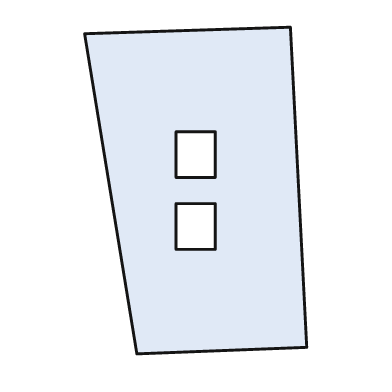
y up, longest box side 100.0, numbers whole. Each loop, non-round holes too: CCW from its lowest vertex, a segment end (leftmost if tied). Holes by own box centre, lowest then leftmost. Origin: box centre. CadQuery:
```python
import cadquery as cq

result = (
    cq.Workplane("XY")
    .moveTo(-18.0, -50.0)
    .lineTo(34.0, -48.0)
    .lineTo(29.0, 50.0)
    .lineTo(-34.0, 48.0)
    .close()
    .moveTo(-6.0, -18.0)
    .lineTo(6.0, -18.0)
    .lineTo(6.0, -4.0)
    .lineTo(-6.0, -4.0)
    .close()
    .moveTo(-6.0, 4.0)
    .lineTo(6.0, 4.0)
    .lineTo(6.0, 18.0)
    .lineTo(-6.0, 18.0)
    .close()
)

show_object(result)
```